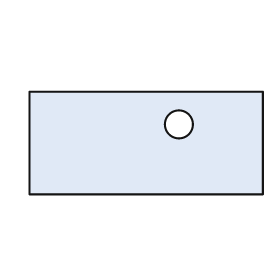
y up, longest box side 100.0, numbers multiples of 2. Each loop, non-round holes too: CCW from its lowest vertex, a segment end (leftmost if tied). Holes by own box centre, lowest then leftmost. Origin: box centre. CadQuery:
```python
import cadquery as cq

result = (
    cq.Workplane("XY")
    .moveTo(-50.0, -22.0)
    .lineTo(50.0, -22.0)
    .lineTo(50.0, 22.0)
    .lineTo(-50.0, 22.0)
    .close()
    .moveTo(14.0, 8.0)
    .circle(6.0)
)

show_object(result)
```